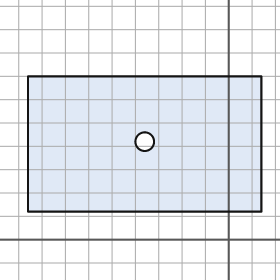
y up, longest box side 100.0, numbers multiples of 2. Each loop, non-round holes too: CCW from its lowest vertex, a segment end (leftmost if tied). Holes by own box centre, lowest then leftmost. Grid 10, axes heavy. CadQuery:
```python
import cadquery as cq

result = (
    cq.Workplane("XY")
    .moveTo(-86.0, 12.0)
    .lineTo(14.0, 12.0)
    .lineTo(14.0, 70.0)
    .lineTo(-86.0, 70.0)
    .close()
    .moveTo(-36.0, 42.0)
    .circle(4.0)
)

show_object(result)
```